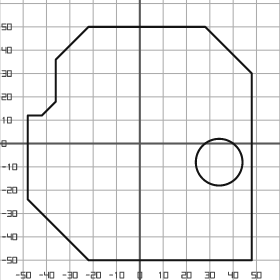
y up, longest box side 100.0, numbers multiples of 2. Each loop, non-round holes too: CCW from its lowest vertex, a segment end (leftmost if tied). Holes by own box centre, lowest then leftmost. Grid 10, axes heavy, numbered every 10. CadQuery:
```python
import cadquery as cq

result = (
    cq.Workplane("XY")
    .moveTo(-22.0, -50.0)
    .lineTo(48.0, -50.0)
    .lineTo(48.0, 30.0)
    .lineTo(28.0, 50.0)
    .lineTo(-22.0, 50.0)
    .lineTo(-36.0, 36.0)
    .lineTo(-36.0, 18.0)
    .lineTo(-42.0, 12.0)
    .lineTo(-48.0, 12.0)
    .lineTo(-48.0, -24.0)
    .close()
    .moveTo(34.0, -8.0)
    .circle(10.0)
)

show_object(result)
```